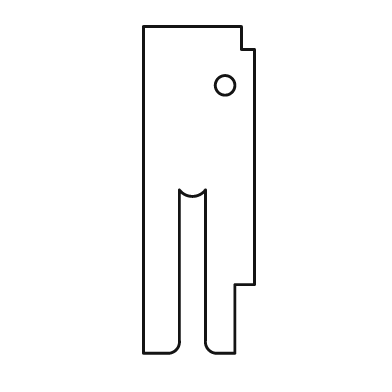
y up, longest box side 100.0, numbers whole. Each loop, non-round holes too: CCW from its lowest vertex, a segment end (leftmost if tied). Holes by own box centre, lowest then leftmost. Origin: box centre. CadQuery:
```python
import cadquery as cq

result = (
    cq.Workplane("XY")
    .moveTo(-17.0, -50.0)
    .lineTo(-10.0, -50.0)
    .threePointArc((-7.0, -49.0), (-6.0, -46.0))
    .lineTo(-6.0, 0.0)
    .threePointArc((-2.0, -2.0), (2.0, 0.0))
    .lineTo(2.0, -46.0)
    .threePointArc((3.0, -49.0), (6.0, -50.0))
    .lineTo(11.0, -50.0)
    .lineTo(11.0, -29.0)
    .lineTo(17.0, -29.0)
    .lineTo(17.0, 43.0)
    .lineTo(13.0, 43.0)
    .lineTo(13.0, 50.0)
    .lineTo(-17.0, 50.0)
    .close()
    .moveTo(8.0, 32.0)
    .circle(3.0)
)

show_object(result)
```